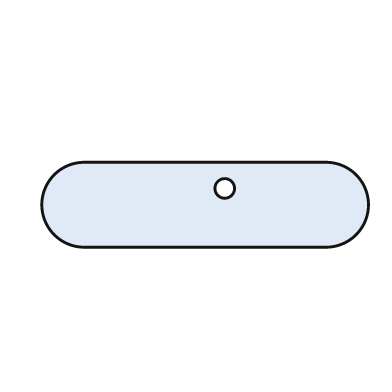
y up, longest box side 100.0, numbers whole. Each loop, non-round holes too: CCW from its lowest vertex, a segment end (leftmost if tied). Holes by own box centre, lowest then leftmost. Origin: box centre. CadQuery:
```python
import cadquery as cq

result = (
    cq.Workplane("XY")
    .moveTo(-37.0, -13.0)
    .lineTo(37.0, -13.0)
    .threePointArc((50.0, 0.0), (37.0, 13.0))
    .lineTo(-37.0, 13.0)
    .threePointArc((-50.0, 0.0), (-37.0, -13.0))
    .close()
    .moveTo(6.0, 5.0)
    .circle(3.0)
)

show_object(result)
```